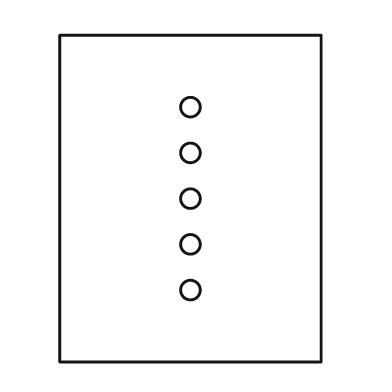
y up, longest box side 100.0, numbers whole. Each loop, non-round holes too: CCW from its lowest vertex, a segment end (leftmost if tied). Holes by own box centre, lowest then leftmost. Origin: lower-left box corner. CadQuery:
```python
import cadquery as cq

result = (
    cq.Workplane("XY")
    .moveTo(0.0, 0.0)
    .lineTo(80.0, 0.0)
    .lineTo(80.0, 100.0)
    .lineTo(0.0, 100.0)
    .close()
    .moveTo(40.0, 22.0)
    .circle(3.0)
    .moveTo(40.0, 36.0)
    .circle(3.0)
    .moveTo(40.0, 50.0)
    .circle(3.0)
    .moveTo(40.0, 64.0)
    .circle(3.0)
    .moveTo(40.0, 78.0)
    .circle(3.0)
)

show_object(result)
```